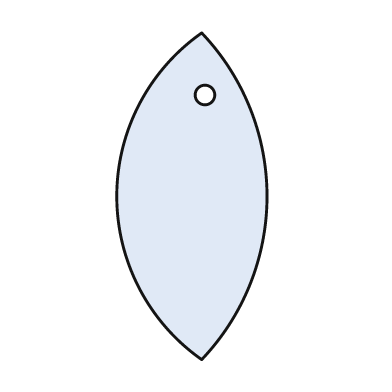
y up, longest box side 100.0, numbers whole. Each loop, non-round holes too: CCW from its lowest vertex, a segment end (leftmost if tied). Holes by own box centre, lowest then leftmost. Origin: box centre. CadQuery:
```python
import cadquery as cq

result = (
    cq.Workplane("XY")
    .moveTo(3.0, -50.0)
    .threePointArc((23.0, 0.0), (3.0, 50.0))
    .threePointArc((-23.0, 0.0), (3.0, -50.0))
    .close()
    .moveTo(4.0, 31.0)
    .circle(3.0)
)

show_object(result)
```